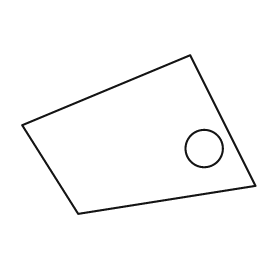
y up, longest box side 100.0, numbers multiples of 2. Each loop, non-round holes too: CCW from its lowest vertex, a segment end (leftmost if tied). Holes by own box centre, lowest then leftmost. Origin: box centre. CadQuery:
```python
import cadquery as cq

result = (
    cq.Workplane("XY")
    .moveTo(-26.0, -34.0)
    .lineTo(50.0, -22.0)
    .lineTo(22.0, 34.0)
    .lineTo(-50.0, 4.0)
    .close()
    .moveTo(28.0, -6.0)
    .circle(8.0)
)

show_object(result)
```